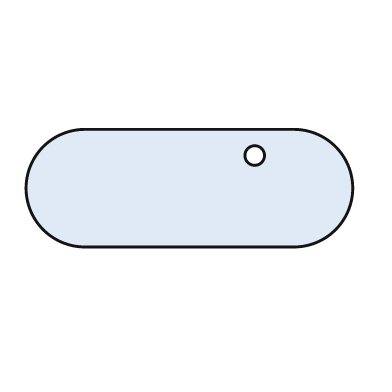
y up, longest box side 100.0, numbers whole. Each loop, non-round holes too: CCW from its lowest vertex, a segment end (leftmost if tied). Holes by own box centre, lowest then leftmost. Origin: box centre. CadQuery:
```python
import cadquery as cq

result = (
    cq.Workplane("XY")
    .moveTo(-32.0, -18.0)
    .lineTo(32.0, -18.0)
    .threePointArc((50.0, 0.0), (32.0, 18.0))
    .lineTo(-32.0, 18.0)
    .threePointArc((-50.0, 0.0), (-32.0, -18.0))
    .close()
    .moveTo(20.0, 10.0)
    .circle(3.0)
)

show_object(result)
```